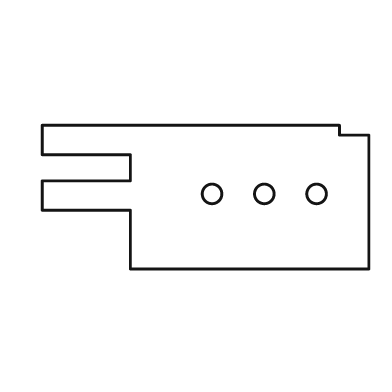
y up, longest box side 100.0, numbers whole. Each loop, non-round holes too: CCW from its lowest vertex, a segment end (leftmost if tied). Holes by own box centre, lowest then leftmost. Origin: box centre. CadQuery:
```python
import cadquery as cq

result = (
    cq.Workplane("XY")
    .moveTo(-23.0, -22.0)
    .lineTo(50.0, -22.0)
    .lineTo(50.0, 19.0)
    .lineTo(41.0, 19.0)
    .lineTo(41.0, 22.0)
    .lineTo(-50.0, 22.0)
    .lineTo(-50.0, 13.0)
    .lineTo(-23.0, 13.0)
    .lineTo(-23.0, 5.0)
    .lineTo(-50.0, 5.0)
    .lineTo(-50.0, -4.0)
    .lineTo(-23.0, -4.0)
    .close()
    .moveTo(2.0, 1.0)
    .circle(3.0)
    .moveTo(18.0, 1.0)
    .circle(3.0)
    .moveTo(34.0, 1.0)
    .circle(3.0)
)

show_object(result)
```